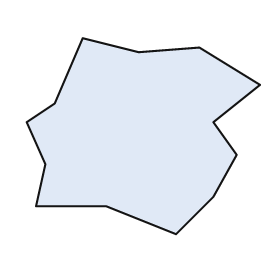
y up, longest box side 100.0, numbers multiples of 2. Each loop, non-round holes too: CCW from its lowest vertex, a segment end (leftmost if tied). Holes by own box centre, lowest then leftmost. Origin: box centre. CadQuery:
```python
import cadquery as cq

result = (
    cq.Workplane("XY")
    .moveTo(14.0, -42.0)
    .lineTo(30.0, -26.0)
    .lineTo(40.0, -8.0)
    .lineTo(30.0, 6.0)
    .lineTo(50.0, 22.0)
    .lineTo(24.0, 38.0)
    .lineTo(-2.0, 36.0)
    .lineTo(-26.0, 42.0)
    .lineTo(-38.0, 14.0)
    .lineTo(-50.0, 6.0)
    .lineTo(-42.0, -12.0)
    .lineTo(-46.0, -30.0)
    .lineTo(-16.0, -30.0)
    .close()
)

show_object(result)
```